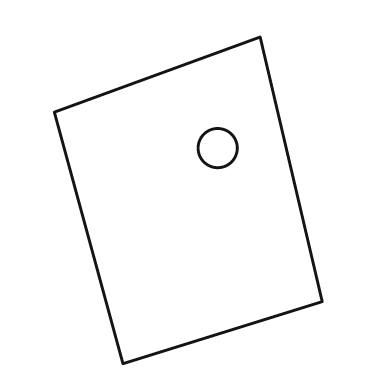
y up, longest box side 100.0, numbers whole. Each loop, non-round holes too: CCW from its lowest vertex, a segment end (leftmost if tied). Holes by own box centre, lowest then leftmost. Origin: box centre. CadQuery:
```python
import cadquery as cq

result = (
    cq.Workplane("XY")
    .moveTo(-20.0, -50.0)
    .lineTo(41.0, -31.0)
    .lineTo(22.0, 50.0)
    .lineTo(-41.0, 27.0)
    .close()
    .moveTo(9.0, 16.0)
    .circle(6.0)
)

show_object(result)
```